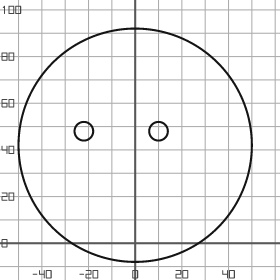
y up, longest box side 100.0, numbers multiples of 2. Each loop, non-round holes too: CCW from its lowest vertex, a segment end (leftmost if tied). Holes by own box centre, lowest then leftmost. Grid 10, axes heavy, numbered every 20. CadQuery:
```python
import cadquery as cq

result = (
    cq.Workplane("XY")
    .moveTo(0.0, 42.0)
    .circle(50.0)
    .moveTo(-22.0, 48.0)
    .circle(4.0)
    .moveTo(10.0, 48.0)
    .circle(4.0)
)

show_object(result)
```